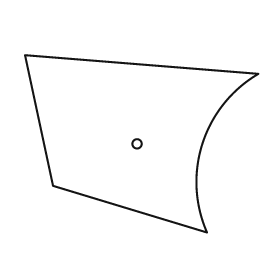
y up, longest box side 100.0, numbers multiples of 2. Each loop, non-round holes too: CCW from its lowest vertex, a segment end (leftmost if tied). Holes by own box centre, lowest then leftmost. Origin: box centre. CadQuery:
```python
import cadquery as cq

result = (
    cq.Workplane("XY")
    .moveTo(28.0, -38.0)
    .threePointArc((26.0, 0.0), (50.0, 30.0))
    .lineTo(-50.0, 38.0)
    .lineTo(-38.0, -18.0)
    .close()
    .moveTo(-2.0, 0.0)
    .circle(2.0)
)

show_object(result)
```